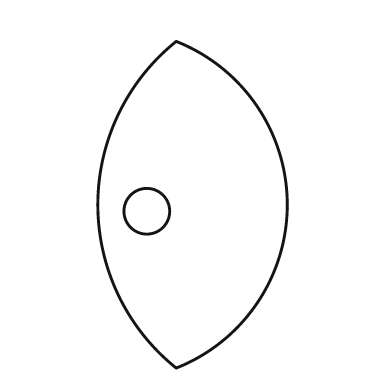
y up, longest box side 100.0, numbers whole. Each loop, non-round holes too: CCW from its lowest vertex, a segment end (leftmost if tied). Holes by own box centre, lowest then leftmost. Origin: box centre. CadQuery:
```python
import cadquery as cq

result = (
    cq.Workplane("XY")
    .moveTo(-5.0, -50.0)
    .threePointArc((29.0, 0.0), (-5.0, 50.0))
    .threePointArc((-29.0, 0.0), (-5.0, -50.0))
    .close()
    .moveTo(-14.0, -2.0)
    .circle(7.0)
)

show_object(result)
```